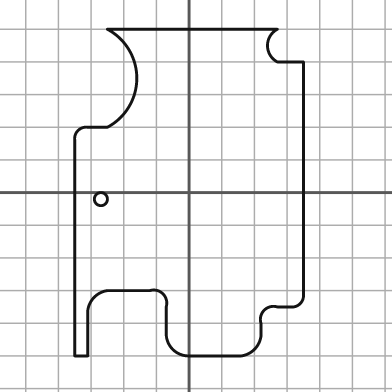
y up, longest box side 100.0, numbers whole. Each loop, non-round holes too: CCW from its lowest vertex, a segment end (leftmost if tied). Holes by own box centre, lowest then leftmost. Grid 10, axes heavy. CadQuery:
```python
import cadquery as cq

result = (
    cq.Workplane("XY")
    .moveTo(-35.0, -50.0)
    .lineTo(-31.0, -50.0)
    .lineTo(-31.0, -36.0)
    .threePointArc((-29.0, -32.0), (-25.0, -30.0))
    .lineTo(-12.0, -30.0)
    .threePointArc((-8.0, -31.0), (-7.0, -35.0))
    .lineTo(-7.0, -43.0)
    .threePointArc((-5.0, -48.0), (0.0, -50.0))
    .lineTo(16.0, -50.0)
    .threePointArc((20.0, -48.0), (22.0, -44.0))
    .lineTo(22.0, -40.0)
    .threePointArc((23.0, -36.0), (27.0, -35.0))
    .lineTo(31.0, -35.0)
    .threePointArc((34.0, -34.0), (35.0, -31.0))
    .lineTo(35.0, 40.0)
    .lineTo(27.0, 40.0)
    .threePointArc((24.0, 45.0), (27.0, 50.0))
    .lineTo(-25.0, 50.0)
    .threePointArc((-16.0, 35.0), (-25.0, 20.0))
    .lineTo(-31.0, 20.0)
    .threePointArc((-34.0, 19.0), (-35.0, 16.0))
    .close()
    .moveTo(-27.0, -2.0)
    .circle(2.0)
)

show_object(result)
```